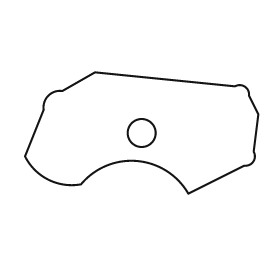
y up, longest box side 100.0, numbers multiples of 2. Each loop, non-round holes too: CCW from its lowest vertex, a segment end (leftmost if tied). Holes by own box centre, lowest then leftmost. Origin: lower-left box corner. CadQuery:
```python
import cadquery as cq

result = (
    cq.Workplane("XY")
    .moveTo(70.0, 0.0)
    .lineTo(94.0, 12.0)
    .threePointArc((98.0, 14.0), (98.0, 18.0))
    .lineTo(100.0, 34.0)
    .lineTo(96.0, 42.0)
    .threePointArc((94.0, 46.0), (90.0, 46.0))
    .lineTo(30.0, 52.0)
    .lineTo(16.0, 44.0)
    .threePointArc((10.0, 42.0), (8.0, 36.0))
    .lineTo(0.0, 16.0)
    .threePointArc((10.0, 6.0), (24.0, 4.0))
    .threePointArc((48.0, 14.0), (70.0, 0.0))
    .close()
    .moveTo(50.0, 26.0)
    .circle(6.0)
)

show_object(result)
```